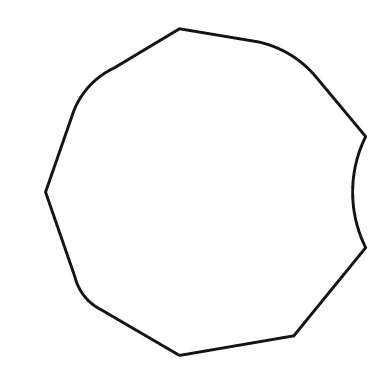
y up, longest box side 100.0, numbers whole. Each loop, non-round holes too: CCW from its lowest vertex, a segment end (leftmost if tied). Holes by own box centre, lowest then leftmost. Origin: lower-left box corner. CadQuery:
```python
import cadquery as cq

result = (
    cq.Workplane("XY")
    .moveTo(41.0, 0.0)
    .lineTo(76.0, 6.0)
    .lineTo(98.0, 33.0)
    .threePointArc((94.0, 50.0), (98.0, 67.0))
    .lineTo(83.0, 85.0)
    .threePointArc((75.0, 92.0), (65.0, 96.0))
    .lineTo(41.0, 100.0)
    .lineTo(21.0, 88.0)
    .threePointArc((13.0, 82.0), (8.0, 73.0))
    .lineTo(0.0, 50.0)
    .lineTo(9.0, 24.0)
    .threePointArc((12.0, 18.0), (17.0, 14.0))
    .close()
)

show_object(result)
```